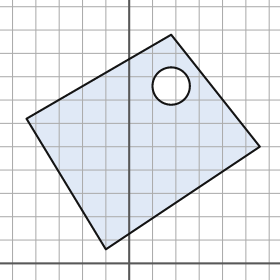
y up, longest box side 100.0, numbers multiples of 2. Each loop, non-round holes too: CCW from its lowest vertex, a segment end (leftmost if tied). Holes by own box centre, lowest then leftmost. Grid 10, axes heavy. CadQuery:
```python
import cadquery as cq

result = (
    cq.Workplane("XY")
    .moveTo(-10.0, 6.0)
    .lineTo(56.0, 50.0)
    .lineTo(18.0, 98.0)
    .lineTo(-44.0, 62.0)
    .close()
    .moveTo(18.0, 76.0)
    .circle(8.0)
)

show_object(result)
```